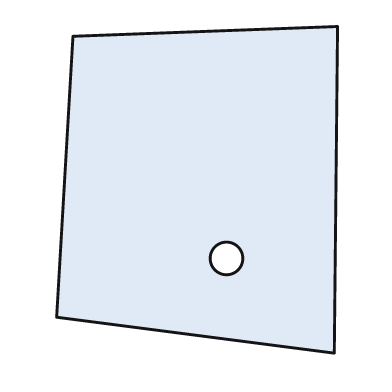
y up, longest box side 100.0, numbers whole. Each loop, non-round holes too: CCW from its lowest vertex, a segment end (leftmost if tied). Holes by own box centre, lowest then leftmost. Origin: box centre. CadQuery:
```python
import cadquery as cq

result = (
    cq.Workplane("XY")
    .moveTo(42.0, -50.0)
    .lineTo(43.0, 50.0)
    .lineTo(-38.0, 47.0)
    .lineTo(-43.0, -39.0)
    .close()
    .moveTo(9.0, -21.0)
    .circle(5.0)
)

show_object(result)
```